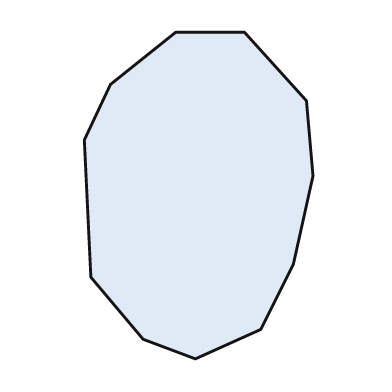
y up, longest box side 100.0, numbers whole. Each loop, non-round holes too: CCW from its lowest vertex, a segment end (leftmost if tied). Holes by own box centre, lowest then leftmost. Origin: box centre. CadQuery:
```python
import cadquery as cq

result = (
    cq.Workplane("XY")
    .moveTo(-1.0, -50.0)
    .lineTo(19.0, -41.0)
    .lineTo(29.0, -21.0)
    .lineTo(35.0, 6.0)
    .lineTo(33.0, 29.0)
    .lineTo(14.0, 50.0)
    .lineTo(-7.0, 50.0)
    .lineTo(-27.0, 34.0)
    .lineTo(-35.0, 17.0)
    .lineTo(-33.0, -25.0)
    .lineTo(-17.0, -44.0)
    .close()
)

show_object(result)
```